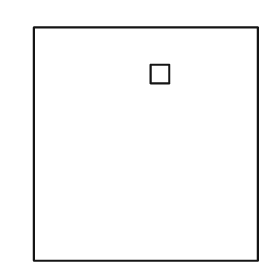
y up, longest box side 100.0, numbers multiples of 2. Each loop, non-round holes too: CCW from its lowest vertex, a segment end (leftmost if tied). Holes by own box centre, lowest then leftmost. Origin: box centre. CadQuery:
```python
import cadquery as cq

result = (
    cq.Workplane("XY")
    .moveTo(-48.0, -50.0)
    .lineTo(48.0, -50.0)
    .lineTo(48.0, 50.0)
    .lineTo(-48.0, 50.0)
    .close()
    .moveTo(2.0, 26.0)
    .lineTo(10.0, 26.0)
    .lineTo(10.0, 34.0)
    .lineTo(2.0, 34.0)
    .close()
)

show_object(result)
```